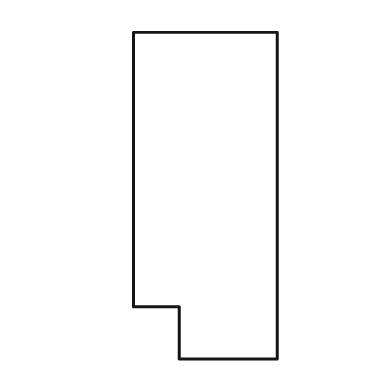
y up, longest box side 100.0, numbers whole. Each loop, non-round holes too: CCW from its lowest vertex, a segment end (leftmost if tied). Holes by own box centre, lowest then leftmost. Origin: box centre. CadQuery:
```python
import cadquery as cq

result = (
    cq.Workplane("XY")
    .moveTo(-8.0, -50.0)
    .lineTo(22.0, -50.0)
    .lineTo(22.0, 50.0)
    .lineTo(-22.0, 50.0)
    .lineTo(-22.0, -34.0)
    .lineTo(-8.0, -34.0)
    .close()
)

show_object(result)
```